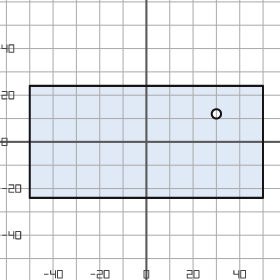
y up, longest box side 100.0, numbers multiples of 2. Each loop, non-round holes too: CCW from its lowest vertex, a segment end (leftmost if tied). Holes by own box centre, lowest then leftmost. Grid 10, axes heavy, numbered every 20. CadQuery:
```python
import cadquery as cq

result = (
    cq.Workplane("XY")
    .moveTo(-50.0, -24.0)
    .lineTo(50.0, -24.0)
    .lineTo(50.0, 24.0)
    .lineTo(-50.0, 24.0)
    .close()
    .moveTo(30.0, 12.0)
    .circle(2.0)
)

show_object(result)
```